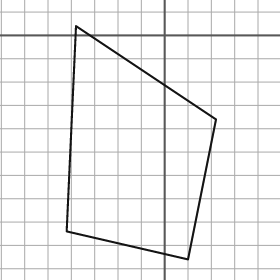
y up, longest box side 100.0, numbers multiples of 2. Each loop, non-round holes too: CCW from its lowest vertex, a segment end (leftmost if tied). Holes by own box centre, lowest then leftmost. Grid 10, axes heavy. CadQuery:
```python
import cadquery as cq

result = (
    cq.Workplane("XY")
    .moveTo(10.0, -96.0)
    .lineTo(22.0, -36.0)
    .lineTo(-38.0, 4.0)
    .lineTo(-42.0, -84.0)
    .close()
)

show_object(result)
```